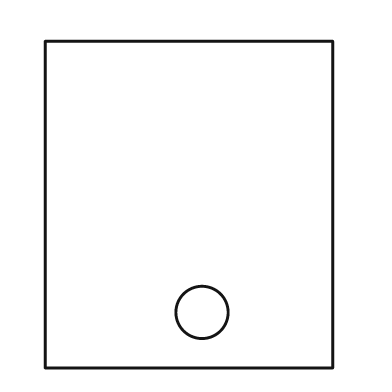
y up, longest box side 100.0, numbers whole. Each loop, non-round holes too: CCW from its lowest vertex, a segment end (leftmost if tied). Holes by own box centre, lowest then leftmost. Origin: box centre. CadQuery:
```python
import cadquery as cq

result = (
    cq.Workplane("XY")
    .moveTo(-44.0, -50.0)
    .lineTo(44.0, -50.0)
    .lineTo(44.0, 50.0)
    .lineTo(-44.0, 50.0)
    .close()
    .moveTo(4.0, -33.0)
    .circle(8.0)
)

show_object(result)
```